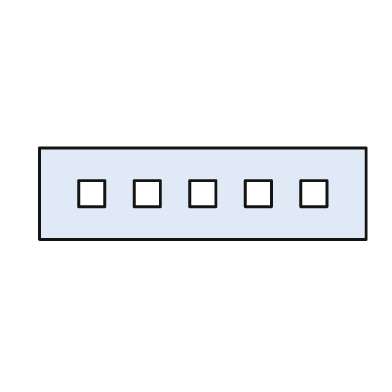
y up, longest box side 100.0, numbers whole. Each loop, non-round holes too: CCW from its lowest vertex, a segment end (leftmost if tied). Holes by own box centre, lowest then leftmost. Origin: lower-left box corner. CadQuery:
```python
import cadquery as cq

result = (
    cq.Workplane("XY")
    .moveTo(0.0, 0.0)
    .lineTo(100.0, 0.0)
    .lineTo(100.0, 28.0)
    .lineTo(0.0, 28.0)
    .close()
    .moveTo(12.0, 10.0)
    .lineTo(20.0, 10.0)
    .lineTo(20.0, 18.0)
    .lineTo(12.0, 18.0)
    .close()
    .moveTo(29.0, 10.0)
    .lineTo(37.0, 10.0)
    .lineTo(37.0, 18.0)
    .lineTo(29.0, 18.0)
    .close()
    .moveTo(46.0, 10.0)
    .lineTo(54.0, 10.0)
    .lineTo(54.0, 18.0)
    .lineTo(46.0, 18.0)
    .close()
    .moveTo(63.0, 10.0)
    .lineTo(71.0, 10.0)
    .lineTo(71.0, 18.0)
    .lineTo(63.0, 18.0)
    .close()
    .moveTo(80.0, 10.0)
    .lineTo(88.0, 10.0)
    .lineTo(88.0, 18.0)
    .lineTo(80.0, 18.0)
    .close()
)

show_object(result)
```